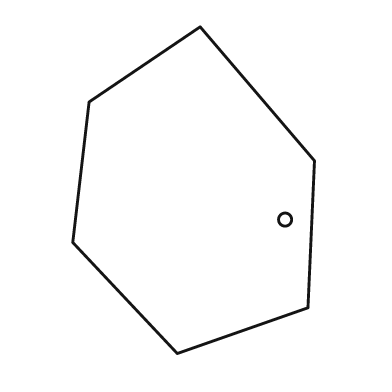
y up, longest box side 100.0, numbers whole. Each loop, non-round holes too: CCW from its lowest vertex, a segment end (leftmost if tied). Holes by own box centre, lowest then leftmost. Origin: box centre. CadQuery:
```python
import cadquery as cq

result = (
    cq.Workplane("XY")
    .moveTo(-5.0, -50.0)
    .lineTo(35.0, -36.0)
    .lineTo(37.0, 9.0)
    .lineTo(2.0, 50.0)
    .lineTo(-32.0, 27.0)
    .lineTo(-37.0, -16.0)
    .close()
    .moveTo(28.0, -9.0)
    .circle(2.0)
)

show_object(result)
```